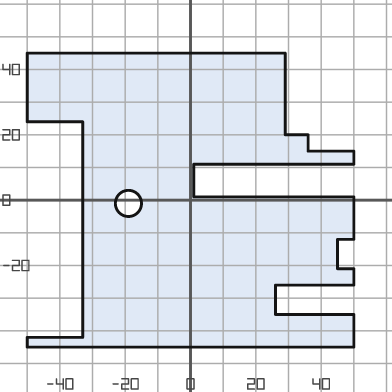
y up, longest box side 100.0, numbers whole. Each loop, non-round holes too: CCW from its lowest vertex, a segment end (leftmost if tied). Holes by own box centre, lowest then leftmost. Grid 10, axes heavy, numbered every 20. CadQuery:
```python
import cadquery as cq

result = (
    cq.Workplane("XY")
    .moveTo(-50.0, -45.0)
    .lineTo(50.0, -45.0)
    .lineTo(50.0, -35.0)
    .lineTo(26.0, -35.0)
    .lineTo(26.0, -26.0)
    .lineTo(50.0, -26.0)
    .lineTo(50.0, -21.0)
    .lineTo(45.0, -21.0)
    .lineTo(45.0, -12.0)
    .lineTo(50.0, -12.0)
    .lineTo(50.0, 1.0)
    .lineTo(1.0, 1.0)
    .lineTo(1.0, 11.0)
    .lineTo(50.0, 11.0)
    .lineTo(50.0, 15.0)
    .lineTo(36.0, 15.0)
    .lineTo(36.0, 20.0)
    .lineTo(29.0, 20.0)
    .lineTo(29.0, 45.0)
    .lineTo(-50.0, 45.0)
    .lineTo(-50.0, 24.0)
    .lineTo(-33.0, 24.0)
    .lineTo(-33.0, -42.0)
    .lineTo(-50.0, -42.0)
    .close()
    .moveTo(-19.0, -1.0)
    .circle(4.0)
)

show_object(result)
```